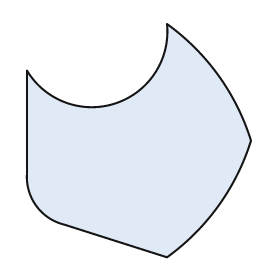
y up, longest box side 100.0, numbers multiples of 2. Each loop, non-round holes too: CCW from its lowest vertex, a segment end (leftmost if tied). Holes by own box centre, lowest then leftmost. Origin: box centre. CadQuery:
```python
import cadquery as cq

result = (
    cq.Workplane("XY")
    .moveTo(12.0, -50.0)
    .threePointArc((34.0, -28.0), (48.0, 0.0))
    .threePointArc((34.0, 28.0), (12.0, 50.0))
    .threePointArc((-10.0, 16.0), (-48.0, 30.0))
    .lineTo(-48.0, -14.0)
    .threePointArc((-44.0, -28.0), (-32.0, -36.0))
    .close()
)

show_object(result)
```